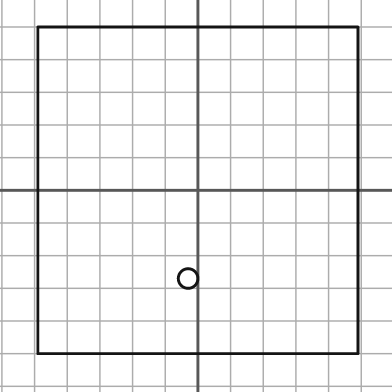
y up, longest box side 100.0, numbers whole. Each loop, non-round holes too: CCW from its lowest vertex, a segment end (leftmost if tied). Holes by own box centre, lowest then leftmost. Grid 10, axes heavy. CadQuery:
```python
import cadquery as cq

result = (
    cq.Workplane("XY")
    .moveTo(-49.0, -50.0)
    .lineTo(49.0, -50.0)
    .lineTo(49.0, 50.0)
    .lineTo(-49.0, 50.0)
    .close()
    .moveTo(-3.0, -27.0)
    .circle(3.0)
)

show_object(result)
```